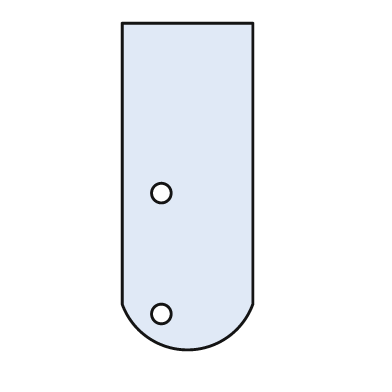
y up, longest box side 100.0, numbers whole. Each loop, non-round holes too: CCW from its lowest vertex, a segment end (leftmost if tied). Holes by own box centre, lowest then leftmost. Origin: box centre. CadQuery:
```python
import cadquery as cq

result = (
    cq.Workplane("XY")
    .moveTo(-20.0, -36.0)
    .threePointArc((0.0, -50.0), (20.0, -36.0))
    .lineTo(20.0, 50.0)
    .lineTo(-20.0, 50.0)
    .close()
    .moveTo(-8.0, -39.0)
    .circle(3.0)
    .moveTo(-8.0, -2.0)
    .circle(3.0)
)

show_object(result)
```